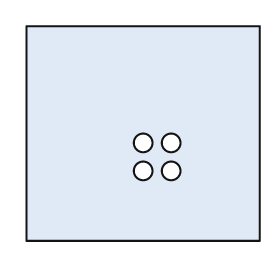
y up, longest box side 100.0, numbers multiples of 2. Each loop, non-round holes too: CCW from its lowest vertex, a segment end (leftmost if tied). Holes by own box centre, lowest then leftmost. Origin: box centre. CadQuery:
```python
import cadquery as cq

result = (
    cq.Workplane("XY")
    .moveTo(-50.0, -46.0)
    .lineTo(50.0, -46.0)
    .lineTo(50.0, 46.0)
    .lineTo(-50.0, 46.0)
    .close()
    .moveTo(0.0, -16.0)
    .circle(4.0)
    .moveTo(12.0, -16.0)
    .circle(4.0)
    .moveTo(0.0, -4.0)
    .circle(4.0)
    .moveTo(12.0, -4.0)
    .circle(4.0)
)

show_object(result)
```